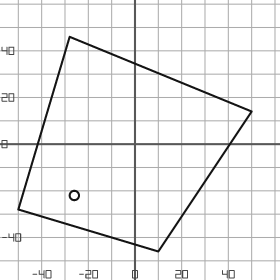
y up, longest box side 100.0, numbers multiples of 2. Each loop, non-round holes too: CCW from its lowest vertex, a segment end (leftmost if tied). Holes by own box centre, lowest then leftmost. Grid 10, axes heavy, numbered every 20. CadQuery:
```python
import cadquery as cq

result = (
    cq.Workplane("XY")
    .moveTo(10.0, -46.0)
    .lineTo(50.0, 14.0)
    .lineTo(-28.0, 46.0)
    .lineTo(-50.0, -28.0)
    .close()
    .moveTo(-26.0, -22.0)
    .circle(2.0)
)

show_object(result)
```